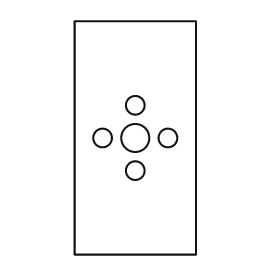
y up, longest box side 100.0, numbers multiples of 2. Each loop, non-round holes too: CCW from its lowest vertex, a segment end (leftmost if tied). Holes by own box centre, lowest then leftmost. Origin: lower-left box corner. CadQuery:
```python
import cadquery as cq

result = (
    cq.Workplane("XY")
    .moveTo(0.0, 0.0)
    .lineTo(52.0, 0.0)
    .lineTo(52.0, 100.0)
    .lineTo(0.0, 100.0)
    .close()
    .moveTo(26.0, 36.0)
    .circle(4.0)
    .moveTo(12.0, 50.0)
    .circle(4.0)
    .moveTo(26.0, 50.0)
    .circle(6.0)
    .moveTo(40.0, 50.0)
    .circle(4.0)
    .moveTo(26.0, 64.0)
    .circle(4.0)
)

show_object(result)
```